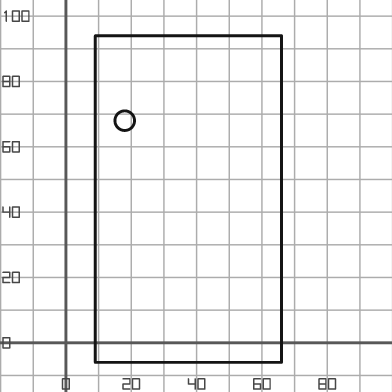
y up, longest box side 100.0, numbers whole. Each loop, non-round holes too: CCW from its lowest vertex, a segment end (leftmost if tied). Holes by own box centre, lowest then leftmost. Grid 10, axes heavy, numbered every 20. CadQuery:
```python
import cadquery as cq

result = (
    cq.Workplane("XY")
    .moveTo(9.0, -6.0)
    .lineTo(66.0, -6.0)
    .lineTo(66.0, 94.0)
    .lineTo(9.0, 94.0)
    .close()
    .moveTo(18.0, 68.0)
    .circle(3.0)
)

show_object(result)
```